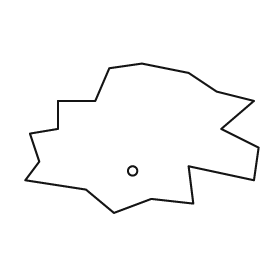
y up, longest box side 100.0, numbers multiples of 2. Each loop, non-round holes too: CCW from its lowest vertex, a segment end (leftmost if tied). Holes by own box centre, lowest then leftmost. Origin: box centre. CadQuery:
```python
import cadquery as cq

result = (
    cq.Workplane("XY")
    .moveTo(-12.0, -32.0)
    .lineTo(4.0, -26.0)
    .lineTo(22.0, -28.0)
    .lineTo(20.0, -12.0)
    .lineTo(48.0, -18.0)
    .lineTo(50.0, -4.0)
    .lineTo(34.0, 4.0)
    .lineTo(48.0, 16.0)
    .lineTo(32.0, 20.0)
    .lineTo(20.0, 28.0)
    .lineTo(0.0, 32.0)
    .lineTo(-14.0, 30.0)
    .lineTo(-20.0, 16.0)
    .lineTo(-36.0, 16.0)
    .lineTo(-36.0, 4.0)
    .lineTo(-48.0, 2.0)
    .lineTo(-44.0, -10.0)
    .lineTo(-50.0, -18.0)
    .lineTo(-24.0, -22.0)
    .close()
    .moveTo(-4.0, -14.0)
    .circle(2.0)
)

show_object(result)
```